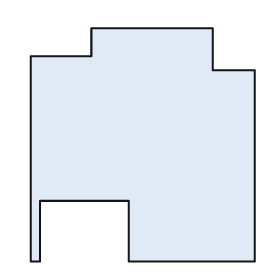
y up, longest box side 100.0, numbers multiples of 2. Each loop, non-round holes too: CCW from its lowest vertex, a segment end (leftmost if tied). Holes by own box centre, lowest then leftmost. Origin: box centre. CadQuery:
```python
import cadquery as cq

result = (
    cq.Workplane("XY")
    .moveTo(-48.0, -50.0)
    .lineTo(-44.0, -50.0)
    .lineTo(-44.0, -24.0)
    .lineTo(-6.0, -24.0)
    .lineTo(-6.0, -50.0)
    .lineTo(48.0, -50.0)
    .lineTo(48.0, 32.0)
    .lineTo(30.0, 32.0)
    .lineTo(30.0, 50.0)
    .lineTo(-22.0, 50.0)
    .lineTo(-22.0, 38.0)
    .lineTo(-48.0, 38.0)
    .close()
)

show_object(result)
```